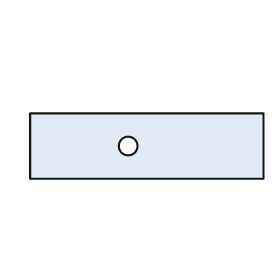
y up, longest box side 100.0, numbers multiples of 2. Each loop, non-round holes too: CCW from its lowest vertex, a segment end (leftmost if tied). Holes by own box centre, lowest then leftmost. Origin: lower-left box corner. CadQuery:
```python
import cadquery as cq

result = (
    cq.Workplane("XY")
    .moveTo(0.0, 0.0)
    .lineTo(100.0, 0.0)
    .lineTo(100.0, 28.0)
    .lineTo(0.0, 28.0)
    .close()
    .moveTo(42.0, 14.0)
    .circle(4.0)
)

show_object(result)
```